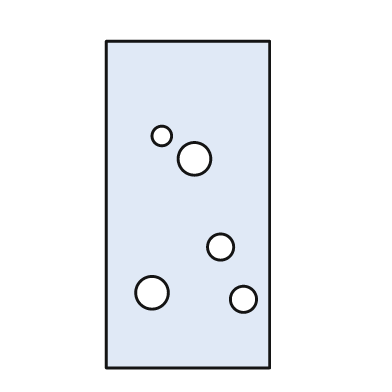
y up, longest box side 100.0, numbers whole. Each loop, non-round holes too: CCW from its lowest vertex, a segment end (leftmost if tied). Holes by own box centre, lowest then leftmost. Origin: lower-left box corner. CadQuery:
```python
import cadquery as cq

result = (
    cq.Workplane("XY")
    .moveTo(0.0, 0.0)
    .lineTo(50.0, 0.0)
    .lineTo(50.0, 100.0)
    .lineTo(0.0, 100.0)
    .close()
    .moveTo(42.0, 21.0)
    .circle(4.0)
    .moveTo(14.0, 23.0)
    .circle(5.0)
    .moveTo(35.0, 37.0)
    .circle(4.0)
    .moveTo(27.0, 64.0)
    .circle(5.0)
    .moveTo(17.0, 71.0)
    .circle(3.0)
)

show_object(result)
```